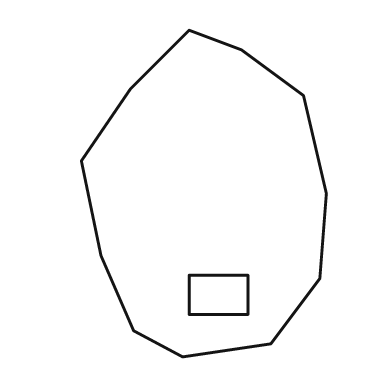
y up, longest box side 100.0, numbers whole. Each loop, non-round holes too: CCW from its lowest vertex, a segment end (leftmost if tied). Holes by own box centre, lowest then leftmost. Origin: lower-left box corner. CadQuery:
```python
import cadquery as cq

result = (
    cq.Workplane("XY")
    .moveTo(31.0, 0.0)
    .lineTo(58.0, 4.0)
    .lineTo(73.0, 24.0)
    .lineTo(75.0, 50.0)
    .lineTo(68.0, 80.0)
    .lineTo(49.0, 94.0)
    .lineTo(33.0, 100.0)
    .lineTo(15.0, 82.0)
    .lineTo(0.0, 60.0)
    .lineTo(6.0, 31.0)
    .lineTo(16.0, 8.0)
    .close()
    .moveTo(33.0, 13.0)
    .lineTo(51.0, 13.0)
    .lineTo(51.0, 25.0)
    .lineTo(33.0, 25.0)
    .close()
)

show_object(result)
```